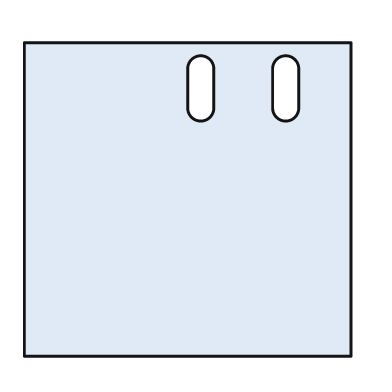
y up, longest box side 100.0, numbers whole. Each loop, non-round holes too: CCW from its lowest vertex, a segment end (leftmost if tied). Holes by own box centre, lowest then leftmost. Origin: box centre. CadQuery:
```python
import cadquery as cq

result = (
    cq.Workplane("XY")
    .moveTo(-50.0, -48.0)
    .lineTo(50.0, -48.0)
    .lineTo(50.0, 48.0)
    .lineTo(-50.0, 48.0)
    .close()
    .moveTo(0.0, 28.0)
    .threePointArc((4.0, 24.0), (8.0, 28.0))
    .lineTo(8.0, 40.0)
    .threePointArc((4.0, 44.0), (0.0, 40.0))
    .close()
    .moveTo(26.0, 28.0)
    .threePointArc((30.0, 24.0), (34.0, 28.0))
    .lineTo(34.0, 40.0)
    .threePointArc((30.0, 44.0), (26.0, 40.0))
    .close()
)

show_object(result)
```